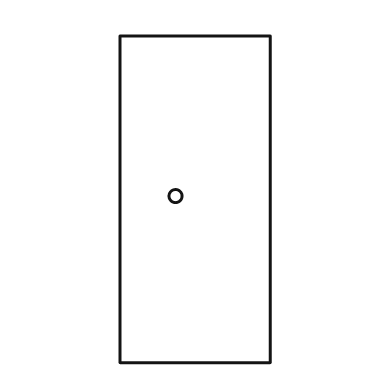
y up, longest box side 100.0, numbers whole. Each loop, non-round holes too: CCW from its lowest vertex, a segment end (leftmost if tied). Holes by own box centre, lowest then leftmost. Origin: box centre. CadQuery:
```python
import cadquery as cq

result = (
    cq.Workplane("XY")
    .moveTo(-23.0, -50.0)
    .lineTo(23.0, -50.0)
    .lineTo(23.0, 50.0)
    .lineTo(-23.0, 50.0)
    .close()
    .moveTo(-6.0, 1.0)
    .circle(2.0)
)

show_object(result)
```